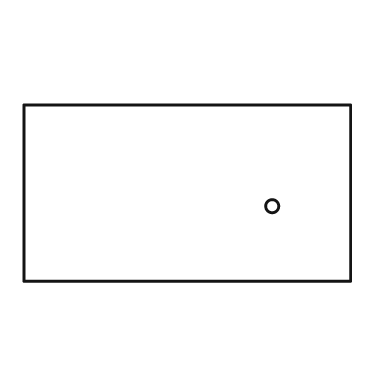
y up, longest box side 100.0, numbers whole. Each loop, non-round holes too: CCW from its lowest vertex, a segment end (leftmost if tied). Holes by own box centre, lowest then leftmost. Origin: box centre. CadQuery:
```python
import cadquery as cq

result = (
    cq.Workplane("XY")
    .moveTo(-50.0, -27.0)
    .lineTo(50.0, -27.0)
    .lineTo(50.0, 27.0)
    .lineTo(-50.0, 27.0)
    .close()
    .moveTo(26.0, -4.0)
    .circle(2.0)
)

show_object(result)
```